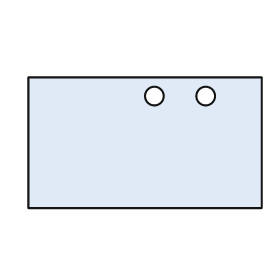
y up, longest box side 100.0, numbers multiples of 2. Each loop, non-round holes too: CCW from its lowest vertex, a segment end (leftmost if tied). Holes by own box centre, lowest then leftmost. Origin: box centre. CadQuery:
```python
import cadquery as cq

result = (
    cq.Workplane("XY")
    .moveTo(-50.0, -28.0)
    .lineTo(50.0, -28.0)
    .lineTo(50.0, 28.0)
    .lineTo(-50.0, 28.0)
    .close()
    .moveTo(4.0, 20.0)
    .circle(4.0)
    .moveTo(26.0, 20.0)
    .circle(4.0)
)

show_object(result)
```